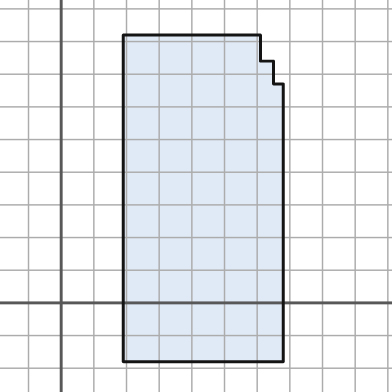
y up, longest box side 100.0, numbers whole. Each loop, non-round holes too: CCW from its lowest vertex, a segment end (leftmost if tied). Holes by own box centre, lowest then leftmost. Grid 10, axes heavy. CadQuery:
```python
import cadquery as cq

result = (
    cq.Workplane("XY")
    .moveTo(19.0, -18.0)
    .lineTo(68.0, -18.0)
    .lineTo(68.0, 67.0)
    .lineTo(65.0, 67.0)
    .lineTo(65.0, 74.0)
    .lineTo(61.0, 74.0)
    .lineTo(61.0, 82.0)
    .lineTo(19.0, 82.0)
    .close()
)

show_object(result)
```